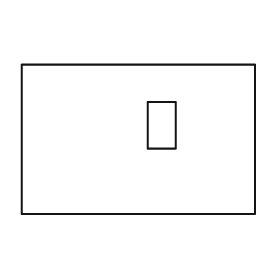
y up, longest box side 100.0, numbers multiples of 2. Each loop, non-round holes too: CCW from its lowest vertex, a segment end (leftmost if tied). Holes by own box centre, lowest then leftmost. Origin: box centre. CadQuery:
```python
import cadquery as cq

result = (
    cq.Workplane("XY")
    .moveTo(-50.0, -32.0)
    .lineTo(50.0, -32.0)
    .lineTo(50.0, 32.0)
    .lineTo(-50.0, 32.0)
    .close()
    .moveTo(4.0, -4.0)
    .lineTo(16.0, -4.0)
    .lineTo(16.0, 16.0)
    .lineTo(4.0, 16.0)
    .close()
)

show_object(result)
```